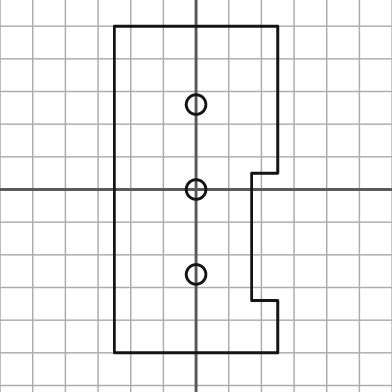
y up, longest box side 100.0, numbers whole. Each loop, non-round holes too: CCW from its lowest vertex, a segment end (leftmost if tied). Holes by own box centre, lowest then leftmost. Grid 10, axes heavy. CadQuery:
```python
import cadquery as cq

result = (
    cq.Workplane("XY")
    .moveTo(-25.0, -50.0)
    .lineTo(25.0, -50.0)
    .lineTo(25.0, -34.0)
    .lineTo(17.0, -34.0)
    .lineTo(17.0, 5.0)
    .lineTo(25.0, 5.0)
    .lineTo(25.0, 50.0)
    .lineTo(-25.0, 50.0)
    .close()
    .moveTo(0.0, -26.0)
    .circle(3.0)
    .moveTo(0.0, 0.0)
    .circle(3.0)
    .moveTo(0.0, 26.0)
    .circle(3.0)
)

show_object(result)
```